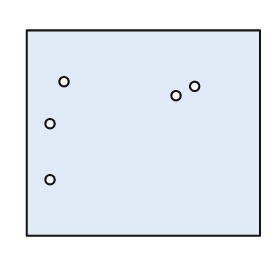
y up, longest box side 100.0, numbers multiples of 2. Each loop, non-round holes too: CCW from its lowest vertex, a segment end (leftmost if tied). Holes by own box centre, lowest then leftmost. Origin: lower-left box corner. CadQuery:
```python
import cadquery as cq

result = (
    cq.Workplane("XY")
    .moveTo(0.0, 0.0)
    .lineTo(100.0, 0.0)
    .lineTo(100.0, 88.0)
    .lineTo(0.0, 88.0)
    .close()
    .moveTo(10.0, 24.0)
    .circle(2.0)
    .moveTo(10.0, 48.0)
    .circle(2.0)
    .moveTo(64.0, 60.0)
    .circle(2.0)
    .moveTo(72.0, 64.0)
    .circle(2.0)
    .moveTo(16.0, 66.0)
    .circle(2.0)
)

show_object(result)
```